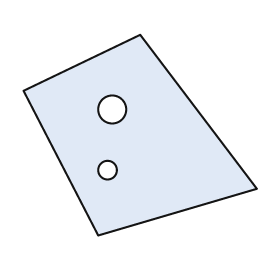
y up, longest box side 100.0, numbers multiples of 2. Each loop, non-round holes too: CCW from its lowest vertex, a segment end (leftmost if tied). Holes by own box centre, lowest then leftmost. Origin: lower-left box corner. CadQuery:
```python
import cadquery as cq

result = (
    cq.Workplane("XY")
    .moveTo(32.0, 0.0)
    .lineTo(100.0, 20.0)
    .lineTo(50.0, 86.0)
    .lineTo(0.0, 62.0)
    .close()
    .moveTo(36.0, 28.0)
    .circle(4.0)
    .moveTo(38.0, 54.0)
    .circle(6.0)
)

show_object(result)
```